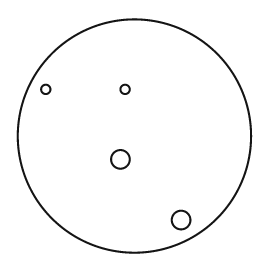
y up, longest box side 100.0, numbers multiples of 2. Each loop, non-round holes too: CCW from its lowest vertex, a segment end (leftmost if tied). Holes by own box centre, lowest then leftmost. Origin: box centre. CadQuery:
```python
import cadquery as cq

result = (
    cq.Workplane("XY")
    .moveTo(0.0, 0.0)
    .circle(50.0)
    .moveTo(20.0, -36.0)
    .circle(4.0)
    .moveTo(-6.0, -10.0)
    .circle(4.0)
    .moveTo(-38.0, 20.0)
    .circle(2.0)
    .moveTo(-4.0, 20.0)
    .circle(2.0)
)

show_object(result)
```